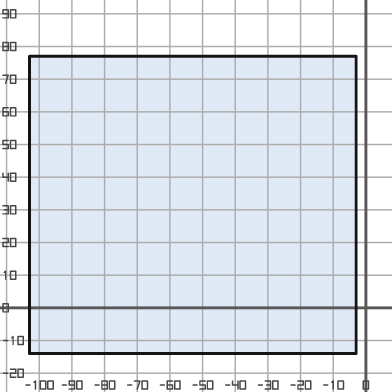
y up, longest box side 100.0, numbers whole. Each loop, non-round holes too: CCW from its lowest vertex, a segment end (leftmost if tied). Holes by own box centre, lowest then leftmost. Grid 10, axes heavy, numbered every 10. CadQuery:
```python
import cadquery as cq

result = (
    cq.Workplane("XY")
    .moveTo(-103.0, -14.0)
    .lineTo(-3.0, -14.0)
    .lineTo(-3.0, 77.0)
    .lineTo(-103.0, 77.0)
    .close()
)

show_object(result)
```